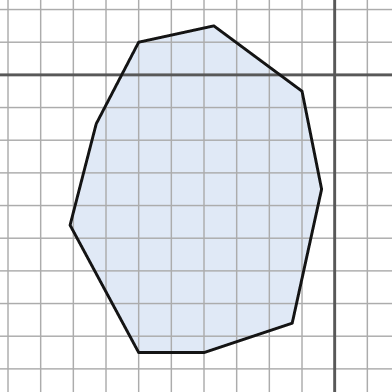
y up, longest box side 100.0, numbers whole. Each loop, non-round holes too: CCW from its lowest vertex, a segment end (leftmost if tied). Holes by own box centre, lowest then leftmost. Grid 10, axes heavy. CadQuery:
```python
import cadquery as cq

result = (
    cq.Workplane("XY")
    .moveTo(-60.0, -85.0)
    .lineTo(-40.0, -85.0)
    .lineTo(-13.0, -76.0)
    .lineTo(-4.0, -35.0)
    .lineTo(-10.0, -5.0)
    .lineTo(-37.0, 15.0)
    .lineTo(-60.0, 10.0)
    .lineTo(-73.0, -15.0)
    .lineTo(-81.0, -46.0)
    .close()
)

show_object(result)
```